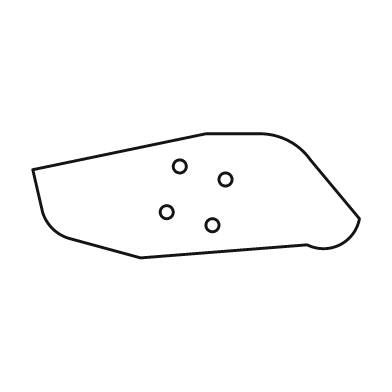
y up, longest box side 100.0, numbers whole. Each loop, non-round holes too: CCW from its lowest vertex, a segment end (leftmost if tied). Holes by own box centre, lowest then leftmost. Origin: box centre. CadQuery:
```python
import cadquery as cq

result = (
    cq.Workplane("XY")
    .moveTo(-17.0, -19.0)
    .lineTo(34.0, -15.0)
    .threePointArc((44.0, -15.0), (50.0, -7.0))
    .lineTo(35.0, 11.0)
    .threePointArc((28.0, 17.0), (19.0, 19.0))
    .lineTo(3.0, 19.0)
    .lineTo(-50.0, 8.0)
    .lineTo(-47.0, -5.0)
    .threePointArc((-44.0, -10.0), (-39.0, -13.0))
    .close()
    .moveTo(5.0, -9.0)
    .circle(2.0)
    .moveTo(-9.0, -5.0)
    .circle(2.0)
    .moveTo(9.0, 5.0)
    .circle(2.0)
    .moveTo(-5.0, 9.0)
    .circle(2.0)
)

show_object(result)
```